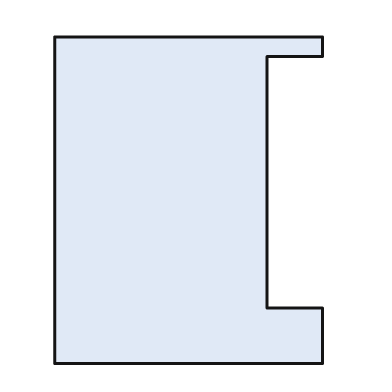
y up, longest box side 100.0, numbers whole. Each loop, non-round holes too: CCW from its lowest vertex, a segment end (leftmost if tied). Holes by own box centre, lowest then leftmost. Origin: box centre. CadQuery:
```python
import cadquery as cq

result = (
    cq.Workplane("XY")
    .moveTo(-41.0, -50.0)
    .lineTo(41.0, -50.0)
    .lineTo(41.0, -33.0)
    .lineTo(24.0, -33.0)
    .lineTo(24.0, 44.0)
    .lineTo(41.0, 44.0)
    .lineTo(41.0, 50.0)
    .lineTo(-41.0, 50.0)
    .close()
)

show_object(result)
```